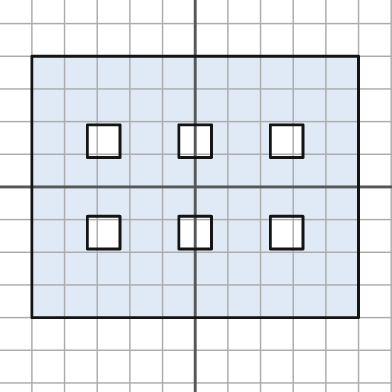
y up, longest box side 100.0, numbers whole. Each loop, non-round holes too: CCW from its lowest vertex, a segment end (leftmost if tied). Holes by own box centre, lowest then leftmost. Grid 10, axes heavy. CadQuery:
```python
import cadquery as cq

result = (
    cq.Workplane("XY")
    .moveTo(-50.0, -40.0)
    .lineTo(50.0, -40.0)
    .lineTo(50.0, 40.0)
    .lineTo(-50.0, 40.0)
    .close()
    .moveTo(-33.0, -19.0)
    .lineTo(-23.0, -19.0)
    .lineTo(-23.0, -9.0)
    .lineTo(-33.0, -9.0)
    .close()
    .moveTo(-5.0, -19.0)
    .lineTo(5.0, -19.0)
    .lineTo(5.0, -9.0)
    .lineTo(-5.0, -9.0)
    .close()
    .moveTo(23.0, -19.0)
    .lineTo(33.0, -19.0)
    .lineTo(33.0, -9.0)
    .lineTo(23.0, -9.0)
    .close()
    .moveTo(-33.0, 9.0)
    .lineTo(-23.0, 9.0)
    .lineTo(-23.0, 19.0)
    .lineTo(-33.0, 19.0)
    .close()
    .moveTo(-5.0, 9.0)
    .lineTo(5.0, 9.0)
    .lineTo(5.0, 19.0)
    .lineTo(-5.0, 19.0)
    .close()
    .moveTo(23.0, 9.0)
    .lineTo(33.0, 9.0)
    .lineTo(33.0, 19.0)
    .lineTo(23.0, 19.0)
    .close()
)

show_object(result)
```